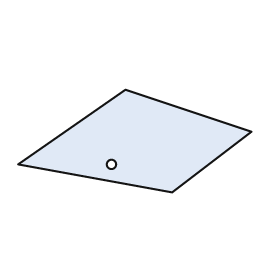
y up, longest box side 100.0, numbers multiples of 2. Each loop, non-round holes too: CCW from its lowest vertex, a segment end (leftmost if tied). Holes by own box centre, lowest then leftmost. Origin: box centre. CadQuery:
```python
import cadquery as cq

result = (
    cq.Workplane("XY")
    .moveTo(16.0, -22.0)
    .lineTo(50.0, 4.0)
    .lineTo(-4.0, 22.0)
    .lineTo(-50.0, -10.0)
    .close()
    .moveTo(-10.0, -10.0)
    .circle(2.0)
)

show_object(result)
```